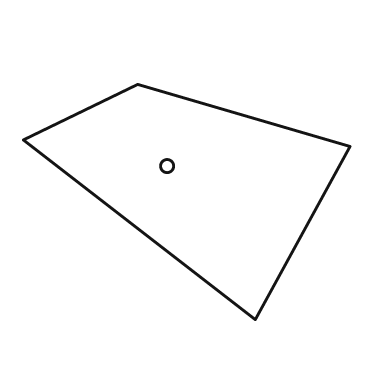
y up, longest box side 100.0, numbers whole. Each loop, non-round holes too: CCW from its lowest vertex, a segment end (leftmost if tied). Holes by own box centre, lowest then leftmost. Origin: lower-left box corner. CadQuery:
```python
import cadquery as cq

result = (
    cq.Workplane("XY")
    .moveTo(71.0, 0.0)
    .lineTo(100.0, 53.0)
    .lineTo(35.0, 72.0)
    .lineTo(0.0, 55.0)
    .close()
    .moveTo(44.0, 47.0)
    .circle(2.0)
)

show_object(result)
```